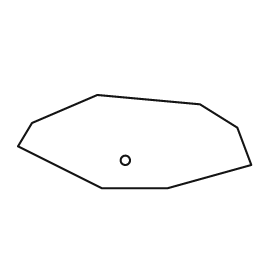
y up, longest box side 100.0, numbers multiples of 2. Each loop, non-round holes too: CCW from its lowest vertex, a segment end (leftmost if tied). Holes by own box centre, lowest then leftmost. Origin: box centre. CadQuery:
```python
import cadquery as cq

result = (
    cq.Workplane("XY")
    .moveTo(-14.0, -20.0)
    .lineTo(14.0, -20.0)
    .lineTo(50.0, -10.0)
    .lineTo(44.0, 6.0)
    .lineTo(28.0, 16.0)
    .lineTo(-16.0, 20.0)
    .lineTo(-44.0, 8.0)
    .lineTo(-50.0, -2.0)
    .close()
    .moveTo(-4.0, -8.0)
    .circle(2.0)
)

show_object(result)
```